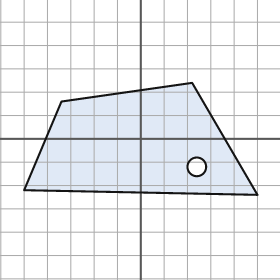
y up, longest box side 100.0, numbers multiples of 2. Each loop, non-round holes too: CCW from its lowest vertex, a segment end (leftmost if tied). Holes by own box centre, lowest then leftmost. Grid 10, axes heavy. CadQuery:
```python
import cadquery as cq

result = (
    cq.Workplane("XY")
    .moveTo(50.0, -24.0)
    .lineTo(22.0, 24.0)
    .lineTo(-34.0, 16.0)
    .lineTo(-50.0, -22.0)
    .close()
    .moveTo(24.0, -12.0)
    .circle(4.0)
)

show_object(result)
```